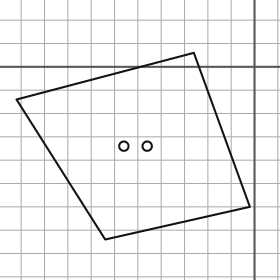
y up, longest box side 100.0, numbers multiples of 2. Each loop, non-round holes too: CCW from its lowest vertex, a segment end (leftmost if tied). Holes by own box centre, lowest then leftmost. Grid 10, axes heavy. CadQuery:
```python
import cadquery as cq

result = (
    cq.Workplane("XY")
    .moveTo(-64.0, -74.0)
    .lineTo(-2.0, -60.0)
    .lineTo(-26.0, 6.0)
    .lineTo(-102.0, -14.0)
    .close()
    .moveTo(-56.0, -34.0)
    .circle(2.0)
    .moveTo(-46.0, -34.0)
    .circle(2.0)
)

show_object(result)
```